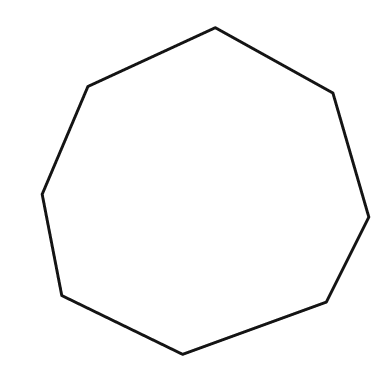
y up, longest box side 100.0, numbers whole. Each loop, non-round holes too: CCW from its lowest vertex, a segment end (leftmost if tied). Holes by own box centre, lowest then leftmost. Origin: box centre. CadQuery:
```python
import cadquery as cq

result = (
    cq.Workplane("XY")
    .moveTo(-7.0, -50.0)
    .lineTo(37.0, -34.0)
    .lineTo(50.0, -8.0)
    .lineTo(39.0, 30.0)
    .lineTo(3.0, 50.0)
    .lineTo(-36.0, 32.0)
    .lineTo(-50.0, -1.0)
    .lineTo(-44.0, -32.0)
    .close()
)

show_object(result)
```